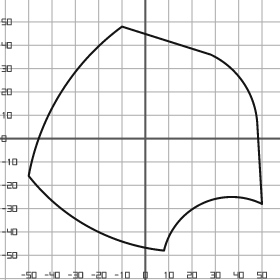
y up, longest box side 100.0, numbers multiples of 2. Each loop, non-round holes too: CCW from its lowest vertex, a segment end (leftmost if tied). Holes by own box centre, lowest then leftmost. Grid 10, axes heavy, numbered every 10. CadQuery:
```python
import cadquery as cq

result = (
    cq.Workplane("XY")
    .moveTo(8.0, -48.0)
    .threePointArc((24.0, -28.0), (50.0, -28.0))
    .lineTo(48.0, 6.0)
    .threePointArc((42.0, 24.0), (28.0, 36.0))
    .lineTo(-10.0, 48.0)
    .threePointArc((-36.0, 20.0), (-50.0, -16.0))
    .threePointArc((-24.0, -38.0), (8.0, -48.0))
    .close()
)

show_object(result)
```